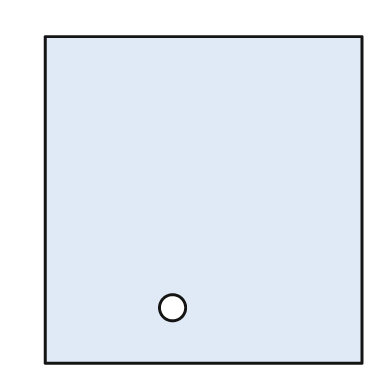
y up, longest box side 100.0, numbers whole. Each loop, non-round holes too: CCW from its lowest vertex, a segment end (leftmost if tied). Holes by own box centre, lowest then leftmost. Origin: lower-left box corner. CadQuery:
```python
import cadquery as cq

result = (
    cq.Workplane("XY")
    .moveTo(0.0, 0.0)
    .lineTo(97.0, 0.0)
    .lineTo(97.0, 100.0)
    .lineTo(0.0, 100.0)
    .close()
    .moveTo(39.0, 17.0)
    .circle(4.0)
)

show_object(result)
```